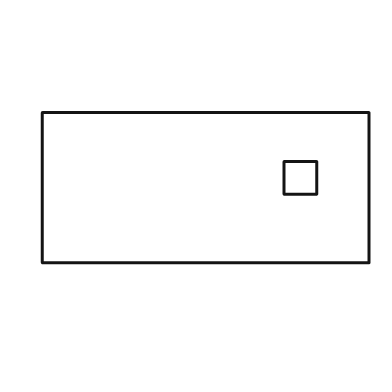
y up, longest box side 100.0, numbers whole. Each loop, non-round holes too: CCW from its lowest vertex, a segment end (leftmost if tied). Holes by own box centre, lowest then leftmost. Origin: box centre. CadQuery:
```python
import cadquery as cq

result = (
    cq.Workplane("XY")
    .moveTo(-50.0, -23.0)
    .lineTo(50.0, -23.0)
    .lineTo(50.0, 23.0)
    .lineTo(-50.0, 23.0)
    .close()
    .moveTo(24.0, -2.0)
    .lineTo(34.0, -2.0)
    .lineTo(34.0, 8.0)
    .lineTo(24.0, 8.0)
    .close()
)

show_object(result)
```